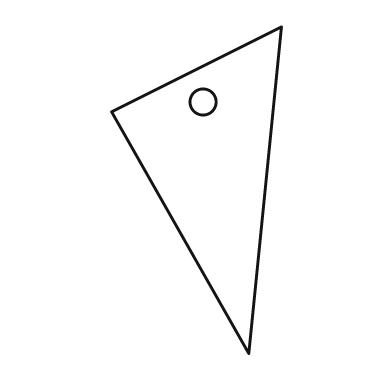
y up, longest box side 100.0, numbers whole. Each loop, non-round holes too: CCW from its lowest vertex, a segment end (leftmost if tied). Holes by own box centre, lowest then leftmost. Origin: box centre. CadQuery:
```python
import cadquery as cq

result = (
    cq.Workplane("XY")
    .moveTo(16.0, -50.0)
    .lineTo(26.0, 50.0)
    .lineTo(-26.0, 24.0)
    .close()
    .moveTo(2.0, 27.0)
    .circle(4.0)
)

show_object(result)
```